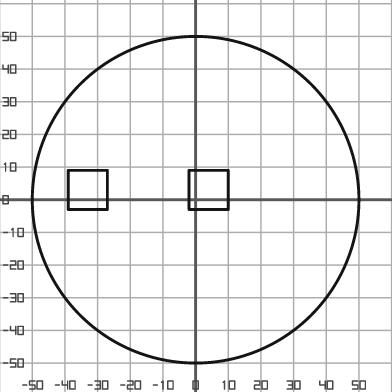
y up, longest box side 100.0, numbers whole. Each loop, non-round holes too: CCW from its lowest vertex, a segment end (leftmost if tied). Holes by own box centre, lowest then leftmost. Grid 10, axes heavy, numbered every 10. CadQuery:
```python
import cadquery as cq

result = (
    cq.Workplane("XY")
    .moveTo(0.0, 0.0)
    .circle(50.0)
    .moveTo(-39.0, -3.0)
    .lineTo(-27.0, -3.0)
    .lineTo(-27.0, 9.0)
    .lineTo(-39.0, 9.0)
    .close()
    .moveTo(-2.0, -3.0)
    .lineTo(10.0, -3.0)
    .lineTo(10.0, 9.0)
    .lineTo(-2.0, 9.0)
    .close()
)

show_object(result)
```